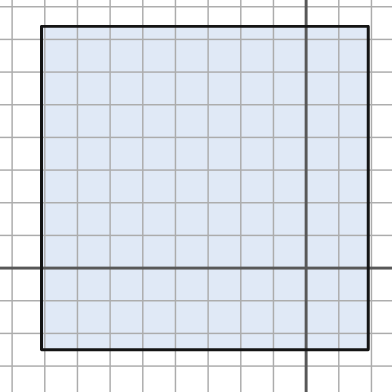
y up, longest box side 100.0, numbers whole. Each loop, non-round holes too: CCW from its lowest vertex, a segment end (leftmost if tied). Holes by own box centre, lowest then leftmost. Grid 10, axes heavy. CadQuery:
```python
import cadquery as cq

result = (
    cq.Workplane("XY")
    .moveTo(-81.0, -25.0)
    .lineTo(19.0, -25.0)
    .lineTo(19.0, 74.0)
    .lineTo(-81.0, 74.0)
    .close()
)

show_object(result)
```